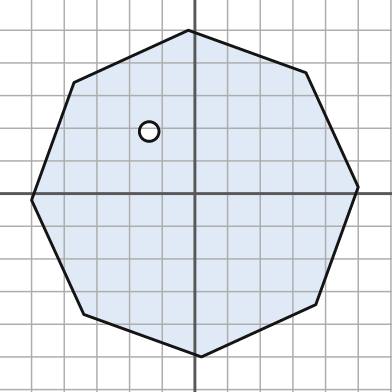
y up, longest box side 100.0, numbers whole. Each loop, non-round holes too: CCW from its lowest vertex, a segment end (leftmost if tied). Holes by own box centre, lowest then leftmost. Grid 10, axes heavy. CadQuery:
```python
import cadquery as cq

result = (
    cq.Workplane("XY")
    .moveTo(2.0, -50.0)
    .lineTo(37.0, -34.0)
    .lineTo(50.0, 2.0)
    .lineTo(34.0, 37.0)
    .lineTo(-2.0, 50.0)
    .lineTo(-37.0, 34.0)
    .lineTo(-50.0, -2.0)
    .lineTo(-34.0, -37.0)
    .close()
    .moveTo(-14.0, 19.0)
    .circle(3.0)
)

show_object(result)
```